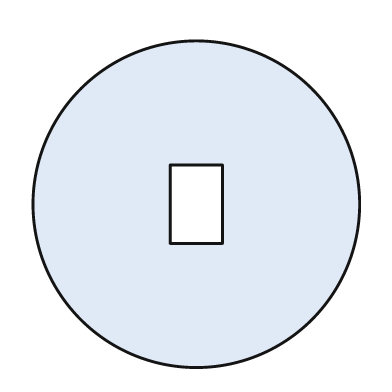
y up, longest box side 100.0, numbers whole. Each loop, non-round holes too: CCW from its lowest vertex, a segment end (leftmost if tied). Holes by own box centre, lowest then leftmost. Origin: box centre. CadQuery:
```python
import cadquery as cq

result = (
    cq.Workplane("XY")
    .moveTo(0.0, 0.0)
    .circle(50.0)
    .moveTo(-8.0, -12.0)
    .lineTo(8.0, -12.0)
    .lineTo(8.0, 12.0)
    .lineTo(-8.0, 12.0)
    .close()
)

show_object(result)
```